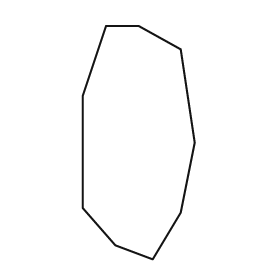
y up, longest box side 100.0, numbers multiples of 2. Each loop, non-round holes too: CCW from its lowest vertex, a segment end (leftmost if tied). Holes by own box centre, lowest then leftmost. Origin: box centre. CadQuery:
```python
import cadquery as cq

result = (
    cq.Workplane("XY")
    .moveTo(6.0, -50.0)
    .lineTo(18.0, -30.0)
    .lineTo(24.0, 0.0)
    .lineTo(18.0, 40.0)
    .lineTo(0.0, 50.0)
    .lineTo(-14.0, 50.0)
    .lineTo(-24.0, 20.0)
    .lineTo(-24.0, -28.0)
    .lineTo(-10.0, -44.0)
    .close()
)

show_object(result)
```